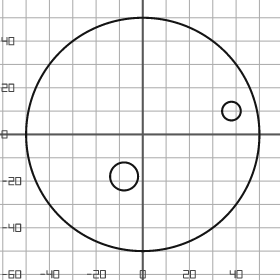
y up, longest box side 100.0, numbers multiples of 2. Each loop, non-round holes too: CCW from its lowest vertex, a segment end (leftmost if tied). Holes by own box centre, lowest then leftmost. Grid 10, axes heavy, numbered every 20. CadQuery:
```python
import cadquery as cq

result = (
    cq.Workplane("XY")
    .moveTo(0.0, 0.0)
    .circle(50.0)
    .moveTo(-8.0, -18.0)
    .circle(6.0)
    .moveTo(38.0, 10.0)
    .circle(4.0)
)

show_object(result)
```